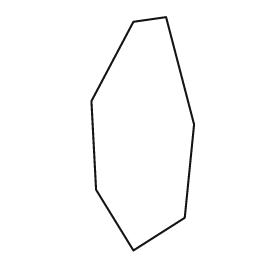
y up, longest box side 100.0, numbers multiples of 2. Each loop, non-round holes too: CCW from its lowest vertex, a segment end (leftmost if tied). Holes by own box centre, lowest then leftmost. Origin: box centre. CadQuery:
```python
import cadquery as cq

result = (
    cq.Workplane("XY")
    .moveTo(-4.0, -50.0)
    .lineTo(18.0, -36.0)
    .lineTo(22.0, 4.0)
    .lineTo(10.0, 50.0)
    .lineTo(-4.0, 48.0)
    .lineTo(-22.0, 14.0)
    .lineTo(-20.0, -24.0)
    .close()
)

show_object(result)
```